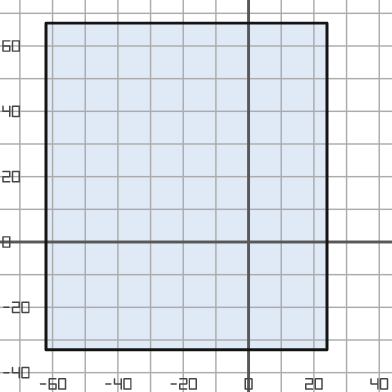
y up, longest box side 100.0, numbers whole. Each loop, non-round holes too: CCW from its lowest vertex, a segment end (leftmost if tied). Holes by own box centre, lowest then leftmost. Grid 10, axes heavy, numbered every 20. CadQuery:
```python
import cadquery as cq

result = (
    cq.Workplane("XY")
    .moveTo(-62.0, -33.0)
    .lineTo(24.0, -33.0)
    .lineTo(24.0, 67.0)
    .lineTo(-62.0, 67.0)
    .close()
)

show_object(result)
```